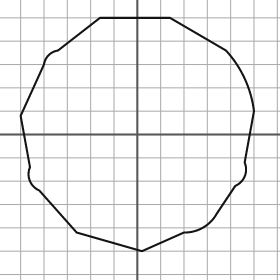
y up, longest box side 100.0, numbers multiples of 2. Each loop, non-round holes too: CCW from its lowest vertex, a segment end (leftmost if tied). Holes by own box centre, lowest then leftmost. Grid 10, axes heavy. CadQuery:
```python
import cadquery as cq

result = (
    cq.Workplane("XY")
    .moveTo(2.0, -50.0)
    .lineTo(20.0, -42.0)
    .threePointArc((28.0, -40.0), (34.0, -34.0))
    .lineTo(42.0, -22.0)
    .threePointArc((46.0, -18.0), (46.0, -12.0))
    .lineTo(50.0, 10.0)
    .threePointArc((46.0, 24.0), (38.0, 36.0))
    .lineTo(14.0, 50.0)
    .lineTo(-16.0, 50.0)
    .lineTo(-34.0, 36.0)
    .threePointArc((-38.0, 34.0), (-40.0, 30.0))
    .lineTo(-50.0, 8.0)
    .lineTo(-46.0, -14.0)
    .threePointArc((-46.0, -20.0), (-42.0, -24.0))
    .lineTo(-26.0, -42.0)
    .close()
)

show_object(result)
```